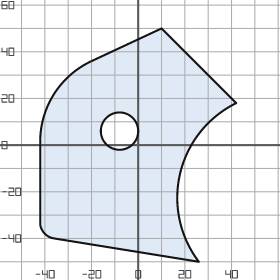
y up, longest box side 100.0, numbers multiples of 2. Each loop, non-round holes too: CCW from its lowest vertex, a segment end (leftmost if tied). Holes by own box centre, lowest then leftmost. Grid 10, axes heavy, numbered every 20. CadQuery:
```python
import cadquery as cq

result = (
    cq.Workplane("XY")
    .moveTo(26.0, -50.0)
    .threePointArc((18.0, -12.0), (42.0, 18.0))
    .lineTo(10.0, 50.0)
    .lineTo(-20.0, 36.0)
    .threePointArc((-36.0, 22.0), (-42.0, 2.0))
    .lineTo(-42.0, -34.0)
    .threePointArc((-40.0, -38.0), (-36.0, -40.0))
    .close()
    .moveTo(-8.0, 6.0)
    .circle(8.0)
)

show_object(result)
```